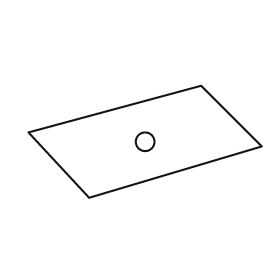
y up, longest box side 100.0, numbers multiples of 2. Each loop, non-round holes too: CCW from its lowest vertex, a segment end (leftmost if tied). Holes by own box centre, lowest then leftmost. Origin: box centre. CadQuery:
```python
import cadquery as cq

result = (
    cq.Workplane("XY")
    .moveTo(-24.0, -24.0)
    .lineTo(50.0, -2.0)
    .lineTo(24.0, 24.0)
    .lineTo(-50.0, 4.0)
    .close()
    .moveTo(0.0, 0.0)
    .circle(4.0)
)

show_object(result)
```